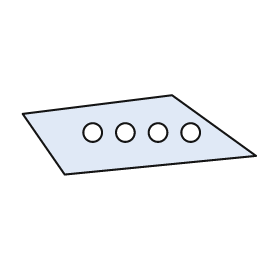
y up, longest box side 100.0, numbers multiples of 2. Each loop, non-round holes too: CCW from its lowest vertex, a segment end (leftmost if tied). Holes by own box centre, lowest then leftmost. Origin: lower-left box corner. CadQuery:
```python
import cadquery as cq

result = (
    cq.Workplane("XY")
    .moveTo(18.0, 0.0)
    .lineTo(100.0, 8.0)
    .lineTo(64.0, 34.0)
    .lineTo(0.0, 26.0)
    .close()
    .moveTo(30.0, 18.0)
    .circle(4.0)
    .moveTo(44.0, 18.0)
    .circle(4.0)
    .moveTo(58.0, 18.0)
    .circle(4.0)
    .moveTo(72.0, 18.0)
    .circle(4.0)
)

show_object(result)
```